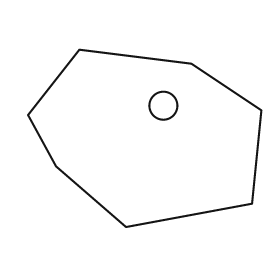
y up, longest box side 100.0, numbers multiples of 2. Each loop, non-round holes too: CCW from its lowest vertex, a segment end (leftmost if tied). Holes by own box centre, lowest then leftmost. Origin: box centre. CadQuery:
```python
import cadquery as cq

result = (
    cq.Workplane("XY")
    .moveTo(-8.0, -38.0)
    .lineTo(46.0, -28.0)
    .lineTo(50.0, 12.0)
    .lineTo(20.0, 32.0)
    .lineTo(-28.0, 38.0)
    .lineTo(-50.0, 10.0)
    .lineTo(-38.0, -12.0)
    .close()
    .moveTo(8.0, 14.0)
    .circle(6.0)
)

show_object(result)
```